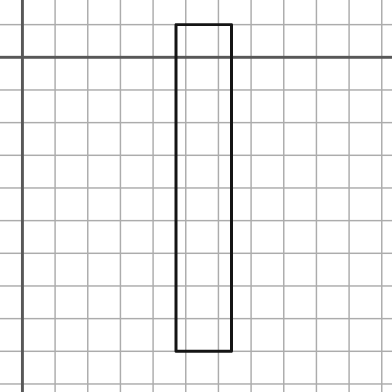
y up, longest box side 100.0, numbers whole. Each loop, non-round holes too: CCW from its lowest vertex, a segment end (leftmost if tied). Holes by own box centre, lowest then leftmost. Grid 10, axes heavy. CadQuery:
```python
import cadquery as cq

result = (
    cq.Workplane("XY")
    .moveTo(47.0, -90.0)
    .lineTo(64.0, -90.0)
    .lineTo(64.0, 10.0)
    .lineTo(47.0, 10.0)
    .close()
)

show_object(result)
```